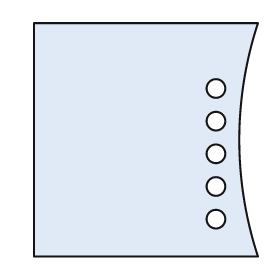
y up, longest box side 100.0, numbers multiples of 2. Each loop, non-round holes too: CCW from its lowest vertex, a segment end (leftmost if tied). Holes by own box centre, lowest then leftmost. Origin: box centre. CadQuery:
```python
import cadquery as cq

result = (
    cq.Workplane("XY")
    .moveTo(-48.0, -50.0)
    .lineTo(48.0, -50.0)
    .threePointArc((40.0, 0.0), (48.0, 50.0))
    .lineTo(-48.0, 50.0)
    .close()
    .moveTo(30.0, -34.0)
    .circle(4.0)
    .moveTo(30.0, -20.0)
    .circle(4.0)
    .moveTo(30.0, -6.0)
    .circle(4.0)
    .moveTo(30.0, 8.0)
    .circle(4.0)
    .moveTo(30.0, 22.0)
    .circle(4.0)
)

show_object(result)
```